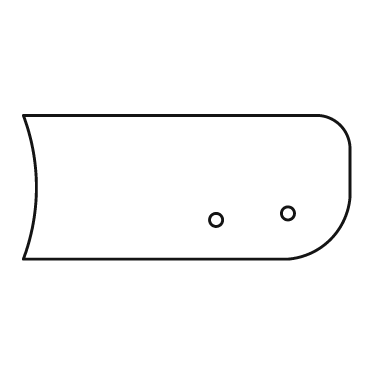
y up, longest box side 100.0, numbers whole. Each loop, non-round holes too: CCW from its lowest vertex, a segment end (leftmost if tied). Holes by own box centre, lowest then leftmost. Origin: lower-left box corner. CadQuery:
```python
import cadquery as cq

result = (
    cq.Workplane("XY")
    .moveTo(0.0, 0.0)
    .lineTo(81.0, 0.0)
    .threePointArc((94.0, 6.0), (100.0, 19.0))
    .lineTo(100.0, 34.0)
    .threePointArc((97.0, 41.0), (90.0, 44.0))
    .lineTo(0.0, 44.0)
    .threePointArc((4.0, 22.0), (0.0, 0.0))
    .close()
    .moveTo(59.0, 12.0)
    .circle(2.0)
    .moveTo(81.0, 14.0)
    .circle(2.0)
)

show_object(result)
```